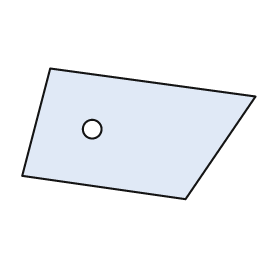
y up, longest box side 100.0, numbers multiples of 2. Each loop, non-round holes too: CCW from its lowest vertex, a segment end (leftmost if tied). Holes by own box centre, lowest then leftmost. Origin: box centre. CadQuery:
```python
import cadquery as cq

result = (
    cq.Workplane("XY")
    .moveTo(20.0, -28.0)
    .lineTo(50.0, 16.0)
    .lineTo(-38.0, 28.0)
    .lineTo(-50.0, -18.0)
    .close()
    .moveTo(-20.0, 2.0)
    .circle(4.0)
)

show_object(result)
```